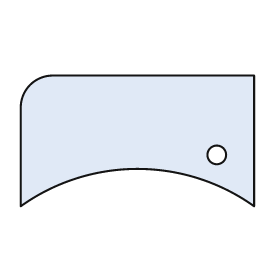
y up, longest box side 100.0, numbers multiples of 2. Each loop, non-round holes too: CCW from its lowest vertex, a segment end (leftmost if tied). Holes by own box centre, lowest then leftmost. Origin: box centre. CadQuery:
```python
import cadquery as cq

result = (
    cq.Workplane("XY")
    .moveTo(-50.0, -28.0)
    .threePointArc((0.0, -12.0), (50.0, -28.0))
    .lineTo(50.0, 28.0)
    .lineTo(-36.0, 28.0)
    .threePointArc((-46.0, 24.0), (-50.0, 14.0))
    .close()
    .moveTo(34.0, -6.0)
    .circle(4.0)
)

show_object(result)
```